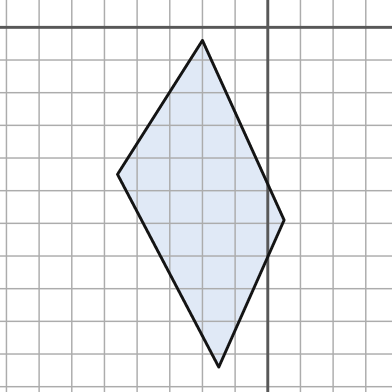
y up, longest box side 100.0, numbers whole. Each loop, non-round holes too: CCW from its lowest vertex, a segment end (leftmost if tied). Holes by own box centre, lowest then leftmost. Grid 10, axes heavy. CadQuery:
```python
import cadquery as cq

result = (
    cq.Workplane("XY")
    .moveTo(-15.0, -104.0)
    .lineTo(5.0, -59.0)
    .lineTo(-20.0, -4.0)
    .lineTo(-46.0, -45.0)
    .close()
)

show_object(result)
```